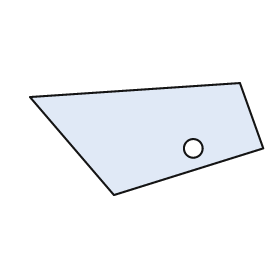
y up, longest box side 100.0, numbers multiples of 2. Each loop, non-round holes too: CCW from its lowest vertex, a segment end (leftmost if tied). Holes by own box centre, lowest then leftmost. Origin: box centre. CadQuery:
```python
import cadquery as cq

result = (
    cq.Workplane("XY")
    .moveTo(-14.0, -24.0)
    .lineTo(50.0, -4.0)
    .lineTo(40.0, 24.0)
    .lineTo(-50.0, 18.0)
    .close()
    .moveTo(20.0, -4.0)
    .circle(4.0)
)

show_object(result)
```